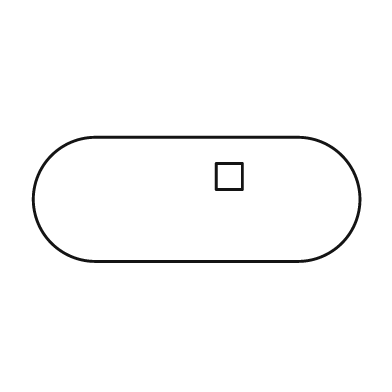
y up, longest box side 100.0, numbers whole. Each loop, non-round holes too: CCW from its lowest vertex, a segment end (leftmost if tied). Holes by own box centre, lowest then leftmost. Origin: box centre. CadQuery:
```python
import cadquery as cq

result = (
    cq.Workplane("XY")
    .moveTo(-31.0, -19.0)
    .lineTo(31.0, -19.0)
    .threePointArc((50.0, 0.0), (31.0, 19.0))
    .lineTo(-31.0, 19.0)
    .threePointArc((-50.0, 0.0), (-31.0, -19.0))
    .close()
    .moveTo(6.0, 3.0)
    .lineTo(14.0, 3.0)
    .lineTo(14.0, 11.0)
    .lineTo(6.0, 11.0)
    .close()
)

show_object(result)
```